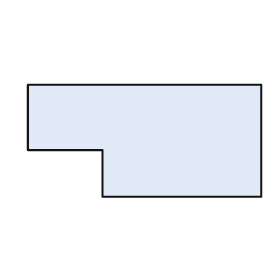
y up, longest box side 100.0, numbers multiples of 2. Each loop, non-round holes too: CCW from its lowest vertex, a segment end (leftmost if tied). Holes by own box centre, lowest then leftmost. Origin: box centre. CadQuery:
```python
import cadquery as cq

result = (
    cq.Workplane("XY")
    .moveTo(-18.0, -24.0)
    .lineTo(50.0, -24.0)
    .lineTo(50.0, 24.0)
    .lineTo(-50.0, 24.0)
    .lineTo(-50.0, -4.0)
    .lineTo(-18.0, -4.0)
    .close()
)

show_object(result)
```